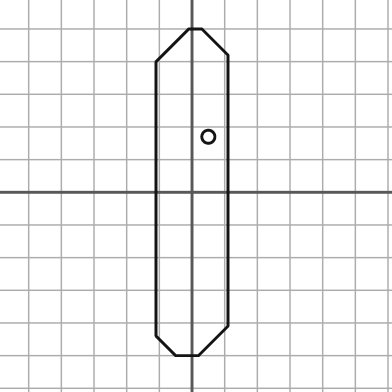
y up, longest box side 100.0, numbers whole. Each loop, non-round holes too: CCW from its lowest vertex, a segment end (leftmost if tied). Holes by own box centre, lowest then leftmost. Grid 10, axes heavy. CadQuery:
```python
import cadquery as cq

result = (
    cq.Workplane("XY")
    .moveTo(-5.0, -50.0)
    .lineTo(2.0, -50.0)
    .lineTo(11.0, -41.0)
    .lineTo(11.0, 42.0)
    .lineTo(3.0, 50.0)
    .lineTo(-1.0, 50.0)
    .lineTo(-11.0, 40.0)
    .lineTo(-11.0, -44.0)
    .close()
    .moveTo(5.0, 17.0)
    .circle(2.0)
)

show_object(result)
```